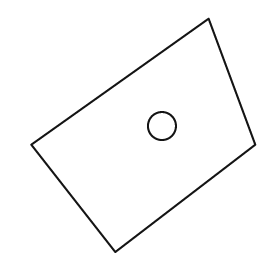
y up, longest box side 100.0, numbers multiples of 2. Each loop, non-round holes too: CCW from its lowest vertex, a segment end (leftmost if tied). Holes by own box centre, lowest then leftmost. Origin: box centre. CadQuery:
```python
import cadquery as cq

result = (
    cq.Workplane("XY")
    .moveTo(-12.0, -50.0)
    .lineTo(48.0, -4.0)
    .lineTo(28.0, 50.0)
    .lineTo(-48.0, -4.0)
    .close()
    .moveTo(8.0, 4.0)
    .circle(6.0)
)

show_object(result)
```